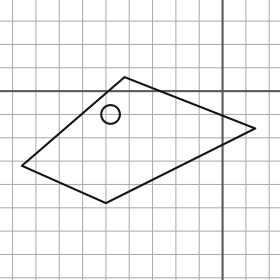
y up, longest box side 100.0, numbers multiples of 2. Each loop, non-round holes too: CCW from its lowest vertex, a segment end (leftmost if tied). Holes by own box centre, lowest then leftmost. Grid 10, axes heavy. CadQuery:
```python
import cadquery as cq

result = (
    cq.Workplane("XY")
    .moveTo(-50.0, -48.0)
    .lineTo(14.0, -16.0)
    .lineTo(-42.0, 6.0)
    .lineTo(-86.0, -32.0)
    .close()
    .moveTo(-48.0, -10.0)
    .circle(4.0)
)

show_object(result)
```